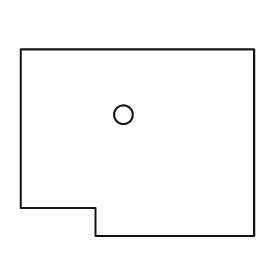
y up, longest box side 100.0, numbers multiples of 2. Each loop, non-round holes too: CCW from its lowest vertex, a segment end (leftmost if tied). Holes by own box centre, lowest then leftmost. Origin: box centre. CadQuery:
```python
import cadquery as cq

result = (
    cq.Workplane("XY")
    .moveTo(-18.0, -40.0)
    .lineTo(50.0, -40.0)
    .lineTo(50.0, 40.0)
    .lineTo(-50.0, 40.0)
    .lineTo(-50.0, -28.0)
    .lineTo(-18.0, -28.0)
    .close()
    .moveTo(-6.0, 12.0)
    .circle(4.0)
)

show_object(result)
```